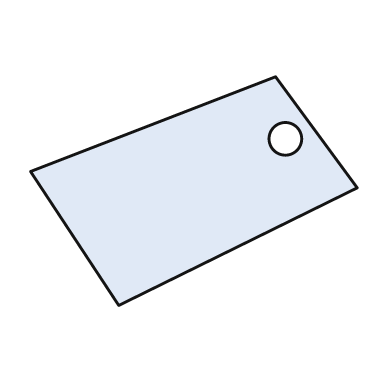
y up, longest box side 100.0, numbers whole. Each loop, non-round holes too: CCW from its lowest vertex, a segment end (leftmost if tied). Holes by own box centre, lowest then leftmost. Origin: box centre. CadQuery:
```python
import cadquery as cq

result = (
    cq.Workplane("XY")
    .moveTo(-23.0, -35.0)
    .lineTo(50.0, 1.0)
    .lineTo(25.0, 35.0)
    .lineTo(-50.0, 6.0)
    .close()
    .moveTo(28.0, 16.0)
    .circle(5.0)
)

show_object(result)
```